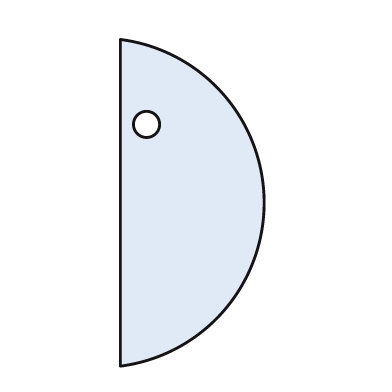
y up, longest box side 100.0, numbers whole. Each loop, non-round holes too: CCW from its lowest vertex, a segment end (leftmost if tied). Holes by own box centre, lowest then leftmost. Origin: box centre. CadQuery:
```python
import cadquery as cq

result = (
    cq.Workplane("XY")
    .moveTo(-22.0, -50.0)
    .threePointArc((22.0, 0.0), (-22.0, 50.0))
    .close()
    .moveTo(-14.0, 24.0)
    .circle(4.0)
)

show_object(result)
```